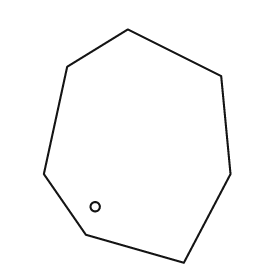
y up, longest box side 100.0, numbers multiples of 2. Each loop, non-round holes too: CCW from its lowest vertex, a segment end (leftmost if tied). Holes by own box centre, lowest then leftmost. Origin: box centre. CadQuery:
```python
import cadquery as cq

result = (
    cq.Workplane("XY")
    .moveTo(20.0, -50.0)
    .lineTo(40.0, -12.0)
    .lineTo(36.0, 30.0)
    .lineTo(-4.0, 50.0)
    .lineTo(-30.0, 34.0)
    .lineTo(-40.0, -12.0)
    .lineTo(-22.0, -38.0)
    .close()
    .moveTo(-18.0, -26.0)
    .circle(2.0)
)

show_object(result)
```